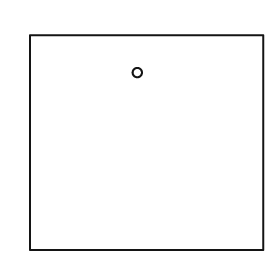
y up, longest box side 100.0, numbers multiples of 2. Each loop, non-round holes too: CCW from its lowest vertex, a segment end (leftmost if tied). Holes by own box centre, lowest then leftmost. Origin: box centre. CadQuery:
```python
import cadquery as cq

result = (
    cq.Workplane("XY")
    .moveTo(-50.0, -46.0)
    .lineTo(50.0, -46.0)
    .lineTo(50.0, 46.0)
    .lineTo(-50.0, 46.0)
    .close()
    .moveTo(-4.0, 30.0)
    .circle(2.0)
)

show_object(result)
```